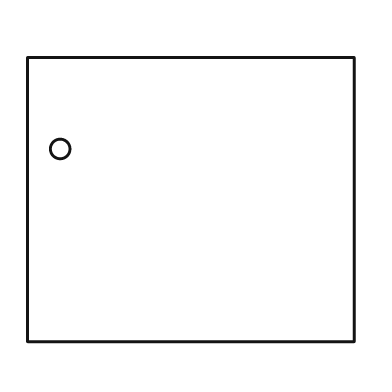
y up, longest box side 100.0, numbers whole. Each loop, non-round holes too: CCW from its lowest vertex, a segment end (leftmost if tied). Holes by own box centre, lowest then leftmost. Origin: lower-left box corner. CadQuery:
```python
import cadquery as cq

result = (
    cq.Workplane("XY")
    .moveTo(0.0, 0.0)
    .lineTo(100.0, 0.0)
    .lineTo(100.0, 87.0)
    .lineTo(0.0, 87.0)
    .close()
    .moveTo(10.0, 59.0)
    .circle(3.0)
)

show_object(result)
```